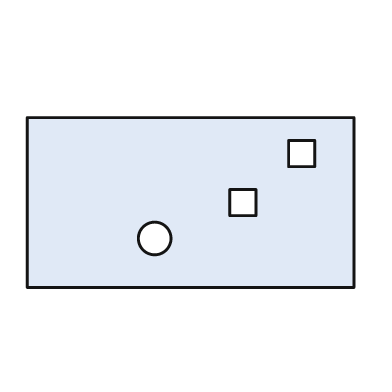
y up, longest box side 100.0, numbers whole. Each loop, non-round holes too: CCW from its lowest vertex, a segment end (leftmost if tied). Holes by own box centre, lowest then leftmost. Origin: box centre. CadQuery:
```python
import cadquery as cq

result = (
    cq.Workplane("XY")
    .moveTo(-50.0, -26.0)
    .lineTo(50.0, -26.0)
    .lineTo(50.0, 26.0)
    .lineTo(-50.0, 26.0)
    .close()
    .moveTo(-11.0, -11.0)
    .circle(5.0)
    .moveTo(12.0, -4.0)
    .lineTo(20.0, -4.0)
    .lineTo(20.0, 4.0)
    .lineTo(12.0, 4.0)
    .close()
    .moveTo(30.0, 11.0)
    .lineTo(38.0, 11.0)
    .lineTo(38.0, 19.0)
    .lineTo(30.0, 19.0)
    .close()
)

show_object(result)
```